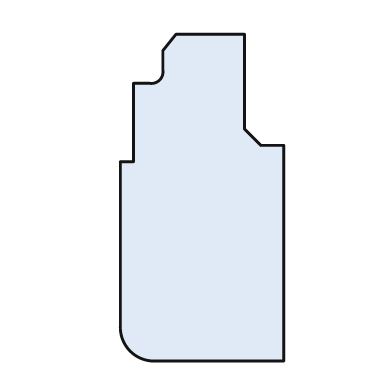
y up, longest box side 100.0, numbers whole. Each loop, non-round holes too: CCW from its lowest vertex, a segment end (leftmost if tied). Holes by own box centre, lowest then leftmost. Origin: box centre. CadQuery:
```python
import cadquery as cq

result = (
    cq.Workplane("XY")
    .moveTo(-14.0, -50.0)
    .lineTo(25.0, -50.0)
    .lineTo(25.0, 16.0)
    .lineTo(18.0, 16.0)
    .lineTo(13.0, 21.0)
    .lineTo(13.0, 50.0)
    .lineTo(-8.0, 50.0)
    .lineTo(-12.0, 45.0)
    .lineTo(-12.0, 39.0)
    .threePointArc((-13.0, 36.0), (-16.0, 35.0))
    .lineTo(-21.0, 35.0)
    .lineTo(-21.0, 11.0)
    .lineTo(-25.0, 11.0)
    .lineTo(-25.0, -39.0)
    .threePointArc((-22.0, -47.0), (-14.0, -50.0))
    .close()
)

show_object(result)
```